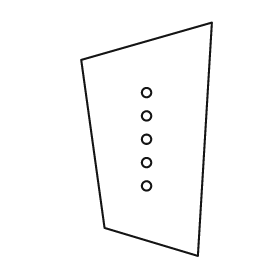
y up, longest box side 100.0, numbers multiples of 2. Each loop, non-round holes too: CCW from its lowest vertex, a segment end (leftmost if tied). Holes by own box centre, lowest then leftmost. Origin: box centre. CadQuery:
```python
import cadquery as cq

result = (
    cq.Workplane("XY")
    .moveTo(22.0, -50.0)
    .lineTo(28.0, 50.0)
    .lineTo(-28.0, 34.0)
    .lineTo(-18.0, -38.0)
    .close()
    .moveTo(0.0, -20.0)
    .circle(2.0)
    .moveTo(0.0, -10.0)
    .circle(2.0)
    .moveTo(0.0, 0.0)
    .circle(2.0)
    .moveTo(0.0, 10.0)
    .circle(2.0)
    .moveTo(0.0, 20.0)
    .circle(2.0)
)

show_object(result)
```